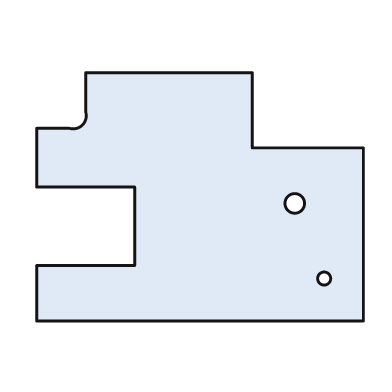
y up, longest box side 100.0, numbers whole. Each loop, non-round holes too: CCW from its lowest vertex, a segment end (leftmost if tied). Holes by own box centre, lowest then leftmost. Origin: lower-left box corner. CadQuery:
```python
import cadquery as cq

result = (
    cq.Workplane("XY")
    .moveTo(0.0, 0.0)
    .lineTo(100.0, 0.0)
    .lineTo(100.0, 53.0)
    .lineTo(66.0, 53.0)
    .lineTo(66.0, 76.0)
    .lineTo(15.0, 76.0)
    .lineTo(15.0, 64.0)
    .threePointArc((14.0, 60.0), (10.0, 59.0))
    .lineTo(0.0, 59.0)
    .lineTo(0.0, 41.0)
    .lineTo(30.0, 41.0)
    .lineTo(30.0, 17.0)
    .lineTo(0.0, 17.0)
    .close()
    .moveTo(88.0, 13.0)
    .circle(2.0)
    .moveTo(79.0, 36.0)
    .circle(3.0)
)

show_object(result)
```